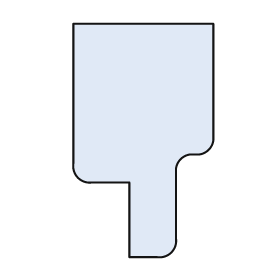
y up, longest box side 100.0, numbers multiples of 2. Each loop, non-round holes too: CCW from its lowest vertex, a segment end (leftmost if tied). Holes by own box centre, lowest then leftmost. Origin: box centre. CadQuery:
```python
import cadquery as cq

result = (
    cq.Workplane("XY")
    .moveTo(-6.0, -50.0)
    .lineTo(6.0, -50.0)
    .threePointArc((12.0, -48.0), (14.0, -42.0))
    .lineTo(14.0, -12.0)
    .threePointArc((16.0, -8.0), (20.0, -6.0))
    .lineTo(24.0, -6.0)
    .threePointArc((28.0, -4.0), (30.0, 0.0))
    .lineTo(30.0, 50.0)
    .lineTo(-30.0, 50.0)
    .lineTo(-30.0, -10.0)
    .threePointArc((-28.0, -16.0), (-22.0, -18.0))
    .lineTo(-6.0, -18.0)
    .close()
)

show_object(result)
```